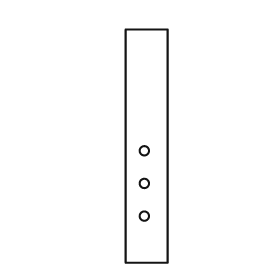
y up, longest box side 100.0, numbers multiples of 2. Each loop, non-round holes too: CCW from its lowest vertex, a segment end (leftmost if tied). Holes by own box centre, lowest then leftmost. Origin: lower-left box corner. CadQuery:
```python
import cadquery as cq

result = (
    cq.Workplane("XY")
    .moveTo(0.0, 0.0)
    .lineTo(18.0, 0.0)
    .lineTo(18.0, 100.0)
    .lineTo(0.0, 100.0)
    .close()
    .moveTo(8.0, 20.0)
    .circle(2.0)
    .moveTo(8.0, 34.0)
    .circle(2.0)
    .moveTo(8.0, 48.0)
    .circle(2.0)
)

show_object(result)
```